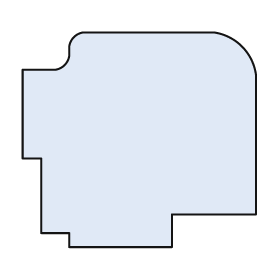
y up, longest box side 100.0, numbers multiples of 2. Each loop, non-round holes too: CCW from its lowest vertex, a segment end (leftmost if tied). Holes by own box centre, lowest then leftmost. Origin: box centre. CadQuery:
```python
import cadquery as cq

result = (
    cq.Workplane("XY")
    .moveTo(-30.0, -46.0)
    .lineTo(14.0, -46.0)
    .lineTo(14.0, -32.0)
    .lineTo(50.0, -32.0)
    .lineTo(50.0, 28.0)
    .threePointArc((44.0, 40.0), (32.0, 46.0))
    .lineTo(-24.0, 46.0)
    .threePointArc((-28.0, 44.0), (-30.0, 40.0))
    .lineTo(-30.0, 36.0)
    .threePointArc((-32.0, 32.0), (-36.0, 30.0))
    .lineTo(-50.0, 30.0)
    .lineTo(-50.0, -8.0)
    .lineTo(-42.0, -8.0)
    .lineTo(-42.0, -40.0)
    .lineTo(-30.0, -40.0)
    .close()
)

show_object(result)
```